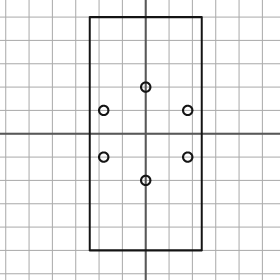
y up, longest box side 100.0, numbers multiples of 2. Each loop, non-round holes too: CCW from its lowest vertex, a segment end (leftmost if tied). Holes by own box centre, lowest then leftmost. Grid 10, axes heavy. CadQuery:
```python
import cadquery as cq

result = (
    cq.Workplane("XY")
    .moveTo(-24.0, -50.0)
    .lineTo(24.0, -50.0)
    .lineTo(24.0, 50.0)
    .lineTo(-24.0, 50.0)
    .close()
    .moveTo(0.0, -20.0)
    .circle(2.0)
    .moveTo(-18.0, -10.0)
    .circle(2.0)
    .moveTo(18.0, -10.0)
    .circle(2.0)
    .moveTo(-18.0, 10.0)
    .circle(2.0)
    .moveTo(18.0, 10.0)
    .circle(2.0)
    .moveTo(0.0, 20.0)
    .circle(2.0)
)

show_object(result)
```